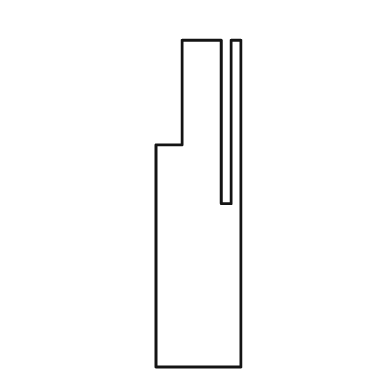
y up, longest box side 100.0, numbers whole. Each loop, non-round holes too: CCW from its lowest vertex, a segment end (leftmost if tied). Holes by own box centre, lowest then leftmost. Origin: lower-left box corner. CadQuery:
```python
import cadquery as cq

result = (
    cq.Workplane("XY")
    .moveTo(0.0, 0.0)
    .lineTo(26.0, 0.0)
    .lineTo(26.0, 100.0)
    .lineTo(23.0, 100.0)
    .lineTo(23.0, 50.0)
    .lineTo(20.0, 50.0)
    .lineTo(20.0, 100.0)
    .lineTo(8.0, 100.0)
    .lineTo(8.0, 68.0)
    .lineTo(0.0, 68.0)
    .close()
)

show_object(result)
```